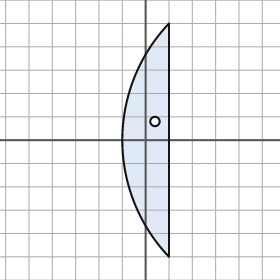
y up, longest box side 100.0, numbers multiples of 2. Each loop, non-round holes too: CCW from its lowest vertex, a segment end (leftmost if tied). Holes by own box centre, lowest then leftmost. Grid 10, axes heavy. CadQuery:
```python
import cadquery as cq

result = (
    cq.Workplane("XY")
    .moveTo(10.0, -50.0)
    .lineTo(10.0, 50.0)
    .threePointArc((-10.0, 0.0), (10.0, -50.0))
    .close()
    .moveTo(4.0, 8.0)
    .circle(2.0)
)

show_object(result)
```